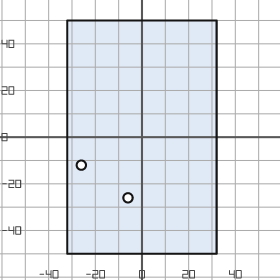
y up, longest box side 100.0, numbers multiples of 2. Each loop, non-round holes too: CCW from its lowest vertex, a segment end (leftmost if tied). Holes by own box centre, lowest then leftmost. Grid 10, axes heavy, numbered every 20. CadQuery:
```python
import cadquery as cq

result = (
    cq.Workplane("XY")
    .moveTo(-32.0, -50.0)
    .lineTo(32.0, -50.0)
    .lineTo(32.0, 50.0)
    .lineTo(-32.0, 50.0)
    .close()
    .moveTo(-6.0, -26.0)
    .circle(2.0)
    .moveTo(-26.0, -12.0)
    .circle(2.0)
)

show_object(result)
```